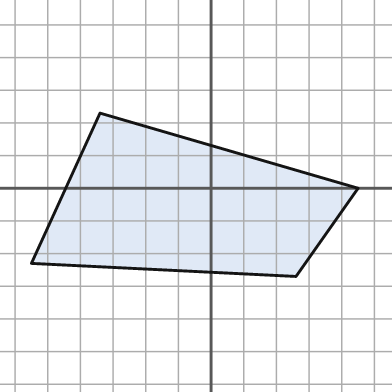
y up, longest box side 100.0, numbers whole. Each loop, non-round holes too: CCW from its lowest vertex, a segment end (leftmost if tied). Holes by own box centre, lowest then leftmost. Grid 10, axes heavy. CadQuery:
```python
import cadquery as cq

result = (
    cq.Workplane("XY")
    .moveTo(26.0, -27.0)
    .lineTo(45.0, 0.0)
    .lineTo(-34.0, 23.0)
    .lineTo(-55.0, -23.0)
    .close()
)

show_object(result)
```